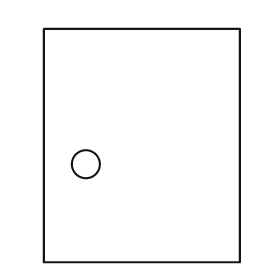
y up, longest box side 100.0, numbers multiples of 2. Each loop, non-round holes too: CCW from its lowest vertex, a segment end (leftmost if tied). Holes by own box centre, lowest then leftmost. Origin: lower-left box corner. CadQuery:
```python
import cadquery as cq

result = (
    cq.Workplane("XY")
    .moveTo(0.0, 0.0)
    .lineTo(84.0, 0.0)
    .lineTo(84.0, 100.0)
    .lineTo(0.0, 100.0)
    .close()
    .moveTo(18.0, 42.0)
    .circle(6.0)
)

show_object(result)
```